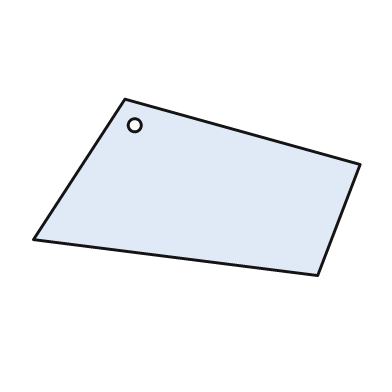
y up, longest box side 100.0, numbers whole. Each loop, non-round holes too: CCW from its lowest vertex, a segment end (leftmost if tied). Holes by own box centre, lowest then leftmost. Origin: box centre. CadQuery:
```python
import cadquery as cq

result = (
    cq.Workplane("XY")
    .moveTo(37.0, -27.0)
    .lineTo(50.0, 7.0)
    .lineTo(-22.0, 27.0)
    .lineTo(-50.0, -16.0)
    .close()
    .moveTo(-19.0, 19.0)
    .circle(2.0)
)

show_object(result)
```